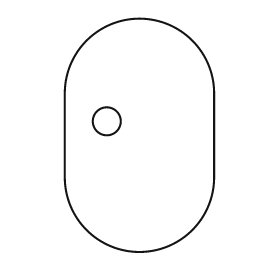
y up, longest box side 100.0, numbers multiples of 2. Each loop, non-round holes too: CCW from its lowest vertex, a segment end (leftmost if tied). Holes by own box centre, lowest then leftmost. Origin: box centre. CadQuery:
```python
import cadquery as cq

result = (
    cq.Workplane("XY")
    .moveTo(-32.0, -18.0)
    .threePointArc((0.0, -50.0), (32.0, -18.0))
    .lineTo(32.0, 18.0)
    .threePointArc((0.0, 50.0), (-32.0, 18.0))
    .close()
    .moveTo(-14.0, 6.0)
    .circle(6.0)
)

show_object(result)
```